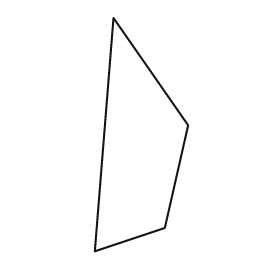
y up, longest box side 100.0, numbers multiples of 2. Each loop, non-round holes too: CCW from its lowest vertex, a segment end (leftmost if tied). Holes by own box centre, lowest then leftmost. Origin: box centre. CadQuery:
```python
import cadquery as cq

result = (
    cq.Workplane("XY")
    .moveTo(-20.0, -50.0)
    .lineTo(10.0, -40.0)
    .lineTo(20.0, 4.0)
    .lineTo(-12.0, 50.0)
    .close()
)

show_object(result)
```